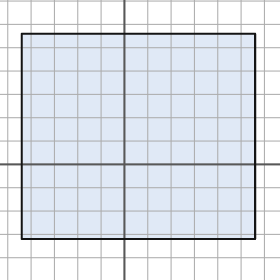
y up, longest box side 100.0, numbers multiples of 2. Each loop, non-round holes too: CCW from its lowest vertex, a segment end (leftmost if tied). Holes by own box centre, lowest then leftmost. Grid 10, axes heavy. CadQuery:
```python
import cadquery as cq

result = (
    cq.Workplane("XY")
    .moveTo(-44.0, -32.0)
    .lineTo(56.0, -32.0)
    .lineTo(56.0, 56.0)
    .lineTo(-44.0, 56.0)
    .close()
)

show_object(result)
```